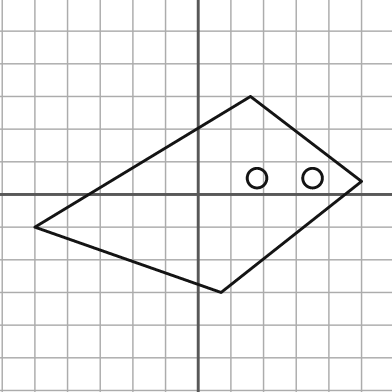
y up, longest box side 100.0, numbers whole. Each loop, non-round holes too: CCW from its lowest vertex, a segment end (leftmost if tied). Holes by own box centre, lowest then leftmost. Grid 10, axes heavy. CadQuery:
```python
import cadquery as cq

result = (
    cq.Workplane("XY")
    .moveTo(7.0, -30.0)
    .lineTo(50.0, 4.0)
    .lineTo(16.0, 30.0)
    .lineTo(-50.0, -10.0)
    .close()
    .moveTo(18.0, 5.0)
    .circle(3.0)
    .moveTo(35.0, 5.0)
    .circle(3.0)
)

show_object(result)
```